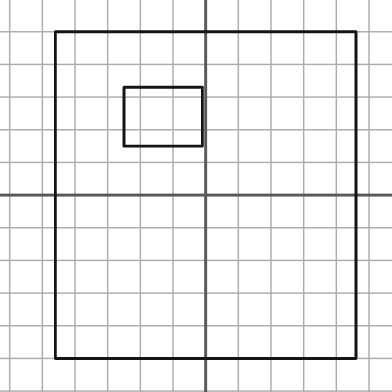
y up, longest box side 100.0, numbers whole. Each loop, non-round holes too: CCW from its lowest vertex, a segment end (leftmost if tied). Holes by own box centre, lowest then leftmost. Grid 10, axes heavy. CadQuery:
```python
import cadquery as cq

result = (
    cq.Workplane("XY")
    .moveTo(-46.0, -50.0)
    .lineTo(46.0, -50.0)
    .lineTo(46.0, 50.0)
    .lineTo(-46.0, 50.0)
    .close()
    .moveTo(-25.0, 15.0)
    .lineTo(-1.0, 15.0)
    .lineTo(-1.0, 33.0)
    .lineTo(-25.0, 33.0)
    .close()
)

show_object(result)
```